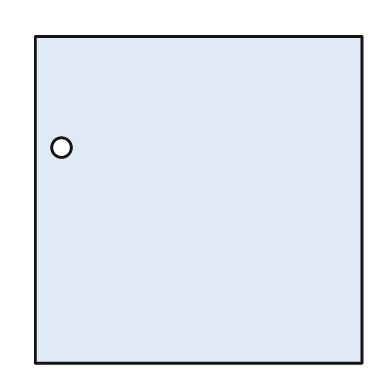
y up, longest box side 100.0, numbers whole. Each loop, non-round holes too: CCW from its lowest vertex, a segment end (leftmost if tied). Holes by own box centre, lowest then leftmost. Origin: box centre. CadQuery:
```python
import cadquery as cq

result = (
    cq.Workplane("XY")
    .moveTo(-50.0, -50.0)
    .lineTo(50.0, -50.0)
    .lineTo(50.0, 50.0)
    .lineTo(-50.0, 50.0)
    .close()
    .moveTo(-42.0, 16.0)
    .circle(3.0)
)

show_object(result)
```